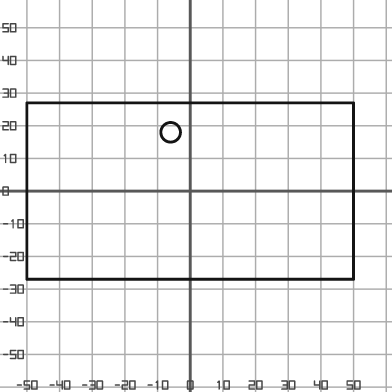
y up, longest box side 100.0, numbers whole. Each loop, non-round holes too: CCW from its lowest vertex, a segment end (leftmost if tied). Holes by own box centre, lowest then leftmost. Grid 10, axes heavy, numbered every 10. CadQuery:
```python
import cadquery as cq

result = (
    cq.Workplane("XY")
    .moveTo(-50.0, -27.0)
    .lineTo(50.0, -27.0)
    .lineTo(50.0, 27.0)
    .lineTo(-50.0, 27.0)
    .close()
    .moveTo(-6.0, 18.0)
    .circle(3.0)
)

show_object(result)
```